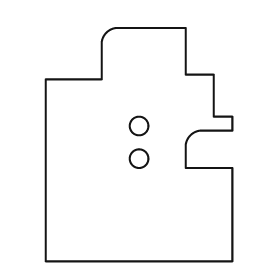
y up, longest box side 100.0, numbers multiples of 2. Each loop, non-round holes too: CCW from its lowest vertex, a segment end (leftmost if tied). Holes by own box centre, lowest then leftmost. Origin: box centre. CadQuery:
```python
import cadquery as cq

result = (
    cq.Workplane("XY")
    .moveTo(-40.0, -50.0)
    .lineTo(40.0, -50.0)
    .lineTo(40.0, -10.0)
    .lineTo(20.0, -10.0)
    .lineTo(20.0, 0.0)
    .threePointArc((22.0, 4.0), (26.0, 6.0))
    .lineTo(40.0, 6.0)
    .lineTo(40.0, 12.0)
    .lineTo(32.0, 12.0)
    .lineTo(32.0, 30.0)
    .lineTo(20.0, 30.0)
    .lineTo(20.0, 50.0)
    .lineTo(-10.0, 50.0)
    .threePointArc((-14.0, 48.0), (-16.0, 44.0))
    .lineTo(-16.0, 28.0)
    .lineTo(-40.0, 28.0)
    .close()
    .moveTo(0.0, -6.0)
    .circle(4.0)
    .moveTo(0.0, 8.0)
    .circle(4.0)
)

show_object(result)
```